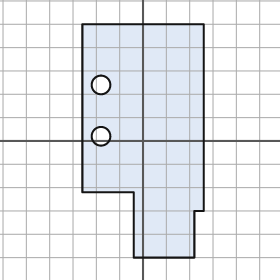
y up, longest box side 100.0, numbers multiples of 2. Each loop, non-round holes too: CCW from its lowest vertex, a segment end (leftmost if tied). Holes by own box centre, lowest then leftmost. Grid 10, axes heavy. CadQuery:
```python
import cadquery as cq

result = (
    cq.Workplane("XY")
    .moveTo(-4.0, -50.0)
    .lineTo(22.0, -50.0)
    .lineTo(22.0, -30.0)
    .lineTo(26.0, -30.0)
    .lineTo(26.0, 50.0)
    .lineTo(-26.0, 50.0)
    .lineTo(-26.0, -22.0)
    .lineTo(-4.0, -22.0)
    .close()
    .moveTo(-18.0, 2.0)
    .circle(4.0)
    .moveTo(-18.0, 24.0)
    .circle(4.0)
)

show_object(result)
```